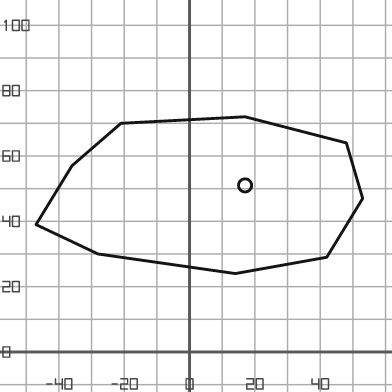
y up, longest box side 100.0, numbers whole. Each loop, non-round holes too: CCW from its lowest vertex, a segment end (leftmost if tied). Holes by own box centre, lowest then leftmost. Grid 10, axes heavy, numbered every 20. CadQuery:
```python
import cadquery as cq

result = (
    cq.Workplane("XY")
    .moveTo(14.0, 24.0)
    .lineTo(42.0, 29.0)
    .lineTo(53.0, 47.0)
    .lineTo(48.0, 64.0)
    .lineTo(17.0, 72.0)
    .lineTo(-21.0, 70.0)
    .lineTo(-36.0, 57.0)
    .lineTo(-47.0, 39.0)
    .lineTo(-28.0, 30.0)
    .close()
    .moveTo(17.0, 51.0)
    .circle(2.0)
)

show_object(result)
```